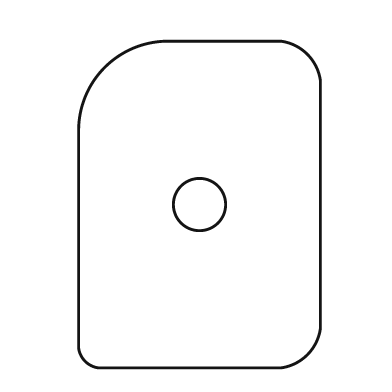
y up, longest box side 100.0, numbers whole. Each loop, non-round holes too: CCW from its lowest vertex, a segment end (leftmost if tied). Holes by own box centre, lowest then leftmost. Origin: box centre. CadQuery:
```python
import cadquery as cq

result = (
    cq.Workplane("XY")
    .moveTo(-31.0, -50.0)
    .lineTo(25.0, -50.0)
    .threePointArc((33.0, -46.0), (37.0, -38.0))
    .lineTo(37.0, 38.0)
    .threePointArc((33.0, 46.0), (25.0, 50.0))
    .lineTo(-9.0, 50.0)
    .threePointArc((-29.0, 42.0), (-37.0, 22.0))
    .lineTo(-37.0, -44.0)
    .threePointArc((-35.0, -48.0), (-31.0, -50.0))
    .close()
    .moveTo(0.0, 0.0)
    .circle(8.0)
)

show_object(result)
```